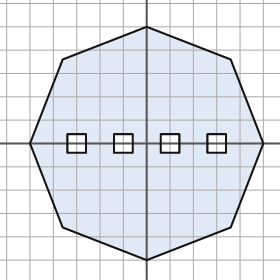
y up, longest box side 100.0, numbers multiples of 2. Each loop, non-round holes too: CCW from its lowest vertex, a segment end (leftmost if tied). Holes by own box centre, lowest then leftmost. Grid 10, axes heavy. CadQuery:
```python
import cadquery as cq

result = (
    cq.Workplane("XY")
    .moveTo(0.0, -50.0)
    .lineTo(36.0, -36.0)
    .lineTo(50.0, 0.0)
    .lineTo(36.0, 36.0)
    .lineTo(0.0, 50.0)
    .lineTo(-36.0, 36.0)
    .lineTo(-50.0, 0.0)
    .lineTo(-36.0, -36.0)
    .close()
    .moveTo(-34.0, -4.0)
    .lineTo(-26.0, -4.0)
    .lineTo(-26.0, 4.0)
    .lineTo(-34.0, 4.0)
    .close()
    .moveTo(-14.0, -4.0)
    .lineTo(-6.0, -4.0)
    .lineTo(-6.0, 4.0)
    .lineTo(-14.0, 4.0)
    .close()
    .moveTo(6.0, -4.0)
    .lineTo(14.0, -4.0)
    .lineTo(14.0, 4.0)
    .lineTo(6.0, 4.0)
    .close()
    .moveTo(26.0, -4.0)
    .lineTo(34.0, -4.0)
    .lineTo(34.0, 4.0)
    .lineTo(26.0, 4.0)
    .close()
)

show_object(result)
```